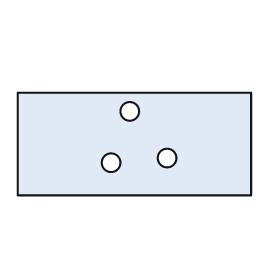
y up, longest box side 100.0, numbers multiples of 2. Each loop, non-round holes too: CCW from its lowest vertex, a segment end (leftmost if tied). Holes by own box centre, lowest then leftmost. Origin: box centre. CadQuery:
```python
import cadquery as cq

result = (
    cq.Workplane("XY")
    .moveTo(-50.0, -22.0)
    .lineTo(50.0, -22.0)
    .lineTo(50.0, 22.0)
    .lineTo(-50.0, 22.0)
    .close()
    .moveTo(-10.0, -8.0)
    .circle(4.0)
    .moveTo(14.0, -6.0)
    .circle(4.0)
    .moveTo(-2.0, 14.0)
    .circle(4.0)
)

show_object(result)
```